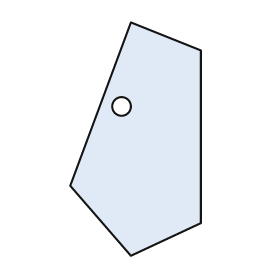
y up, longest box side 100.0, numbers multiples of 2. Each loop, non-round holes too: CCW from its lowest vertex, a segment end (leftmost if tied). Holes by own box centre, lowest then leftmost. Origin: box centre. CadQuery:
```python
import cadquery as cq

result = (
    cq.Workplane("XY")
    .moveTo(-2.0, -50.0)
    .lineTo(28.0, -36.0)
    .lineTo(28.0, 38.0)
    .lineTo(-2.0, 50.0)
    .lineTo(-28.0, -20.0)
    .close()
    .moveTo(-6.0, 14.0)
    .circle(4.0)
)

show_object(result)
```